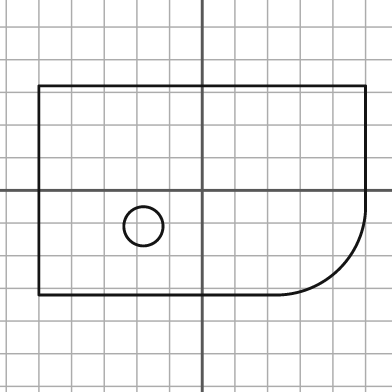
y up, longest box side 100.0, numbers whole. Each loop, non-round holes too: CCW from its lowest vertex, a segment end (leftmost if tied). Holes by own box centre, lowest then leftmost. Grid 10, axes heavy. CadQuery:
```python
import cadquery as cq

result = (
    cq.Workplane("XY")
    .moveTo(-50.0, -32.0)
    .lineTo(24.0, -32.0)
    .threePointArc((42.0, -24.0), (50.0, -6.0))
    .lineTo(50.0, 32.0)
    .lineTo(-50.0, 32.0)
    .close()
    .moveTo(-18.0, -11.0)
    .circle(6.0)
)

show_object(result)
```